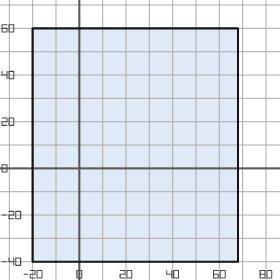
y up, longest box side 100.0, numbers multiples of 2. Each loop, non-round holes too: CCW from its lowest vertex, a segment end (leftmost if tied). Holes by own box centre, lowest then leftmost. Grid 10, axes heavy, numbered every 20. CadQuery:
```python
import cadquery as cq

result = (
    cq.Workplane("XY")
    .moveTo(-20.0, -40.0)
    .lineTo(68.0, -40.0)
    .lineTo(68.0, 60.0)
    .lineTo(-20.0, 60.0)
    .close()
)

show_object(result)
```